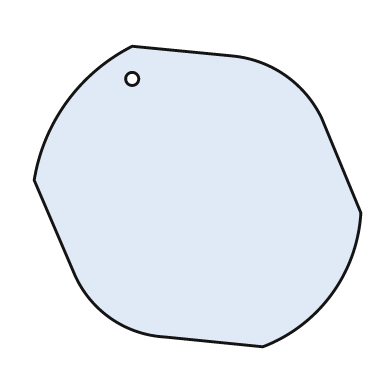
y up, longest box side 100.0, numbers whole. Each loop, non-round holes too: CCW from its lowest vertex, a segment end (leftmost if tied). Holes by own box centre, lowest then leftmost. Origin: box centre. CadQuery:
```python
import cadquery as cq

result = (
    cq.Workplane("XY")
    .moveTo(20.0, -46.0)
    .threePointArc((41.0, -30.0), (50.0, -5.0))
    .lineTo(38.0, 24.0)
    .threePointArc((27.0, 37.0), (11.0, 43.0))
    .lineTo(-20.0, 46.0)
    .threePointArc((-40.0, 29.0), (-50.0, 5.0))
    .lineTo(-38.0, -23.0)
    .threePointArc((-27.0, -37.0), (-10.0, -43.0))
    .close()
    .moveTo(-20.0, 36.0)
    .circle(2.0)
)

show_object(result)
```